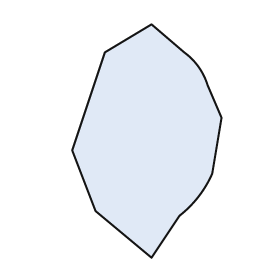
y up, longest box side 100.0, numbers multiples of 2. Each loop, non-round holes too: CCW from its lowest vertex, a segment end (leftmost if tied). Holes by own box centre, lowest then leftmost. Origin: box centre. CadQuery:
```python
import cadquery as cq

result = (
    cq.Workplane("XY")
    .moveTo(2.0, -50.0)
    .lineTo(14.0, -32.0)
    .threePointArc((22.0, -24.0), (28.0, -14.0))
    .lineTo(32.0, 10.0)
    .lineTo(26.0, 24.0)
    .threePointArc((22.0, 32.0), (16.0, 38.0))
    .lineTo(2.0, 50.0)
    .lineTo(-18.0, 38.0)
    .lineTo(-32.0, -4.0)
    .lineTo(-22.0, -30.0)
    .close()
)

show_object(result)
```